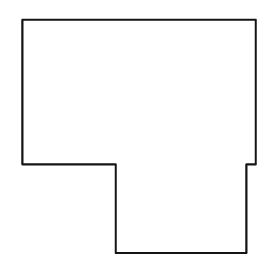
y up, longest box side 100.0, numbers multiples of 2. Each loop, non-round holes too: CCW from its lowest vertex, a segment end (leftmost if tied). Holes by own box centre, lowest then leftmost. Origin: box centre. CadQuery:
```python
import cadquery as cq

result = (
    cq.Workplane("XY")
    .moveTo(-10.0, -50.0)
    .lineTo(46.0, -50.0)
    .lineTo(46.0, -12.0)
    .lineTo(50.0, -12.0)
    .lineTo(50.0, 50.0)
    .lineTo(-50.0, 50.0)
    .lineTo(-50.0, -12.0)
    .lineTo(-10.0, -12.0)
    .close()
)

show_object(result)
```